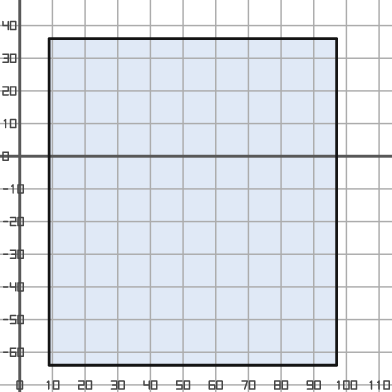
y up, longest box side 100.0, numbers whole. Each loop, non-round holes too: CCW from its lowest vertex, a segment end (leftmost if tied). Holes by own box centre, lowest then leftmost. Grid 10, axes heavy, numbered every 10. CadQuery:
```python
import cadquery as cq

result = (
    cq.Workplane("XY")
    .moveTo(9.0, -64.0)
    .lineTo(97.0, -64.0)
    .lineTo(97.0, 36.0)
    .lineTo(9.0, 36.0)
    .close()
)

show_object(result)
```